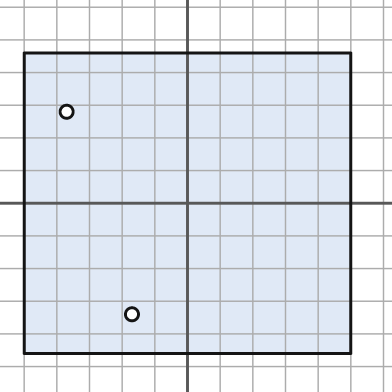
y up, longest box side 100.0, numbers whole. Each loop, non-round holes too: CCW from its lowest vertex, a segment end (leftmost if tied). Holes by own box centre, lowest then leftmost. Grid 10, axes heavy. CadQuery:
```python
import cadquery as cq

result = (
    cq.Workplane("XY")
    .moveTo(-50.0, -46.0)
    .lineTo(50.0, -46.0)
    .lineTo(50.0, 46.0)
    .lineTo(-50.0, 46.0)
    .close()
    .moveTo(-17.0, -34.0)
    .circle(2.0)
    .moveTo(-37.0, 28.0)
    .circle(2.0)
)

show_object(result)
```